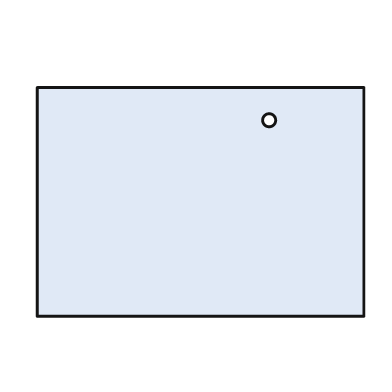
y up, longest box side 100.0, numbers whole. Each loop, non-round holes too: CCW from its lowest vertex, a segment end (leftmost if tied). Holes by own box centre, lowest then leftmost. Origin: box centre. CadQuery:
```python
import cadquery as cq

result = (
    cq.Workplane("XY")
    .moveTo(-50.0, -35.0)
    .lineTo(50.0, -35.0)
    .lineTo(50.0, 35.0)
    .lineTo(-50.0, 35.0)
    .close()
    .moveTo(21.0, 25.0)
    .circle(2.0)
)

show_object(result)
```